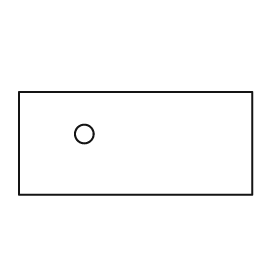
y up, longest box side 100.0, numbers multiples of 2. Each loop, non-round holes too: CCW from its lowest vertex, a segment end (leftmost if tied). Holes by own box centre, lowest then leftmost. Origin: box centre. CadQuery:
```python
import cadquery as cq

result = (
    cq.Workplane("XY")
    .moveTo(-50.0, -22.0)
    .lineTo(50.0, -22.0)
    .lineTo(50.0, 22.0)
    .lineTo(-50.0, 22.0)
    .close()
    .moveTo(-22.0, 4.0)
    .circle(4.0)
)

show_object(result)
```